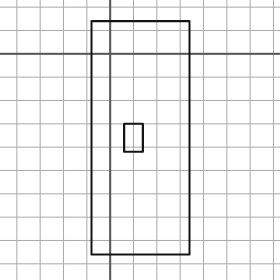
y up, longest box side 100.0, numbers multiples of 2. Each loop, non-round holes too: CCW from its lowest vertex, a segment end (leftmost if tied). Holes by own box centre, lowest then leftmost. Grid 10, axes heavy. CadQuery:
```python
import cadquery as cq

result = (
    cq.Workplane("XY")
    .moveTo(-8.0, -86.0)
    .lineTo(34.0, -86.0)
    .lineTo(34.0, 14.0)
    .lineTo(-8.0, 14.0)
    .close()
    .moveTo(6.0, -42.0)
    .lineTo(14.0, -42.0)
    .lineTo(14.0, -30.0)
    .lineTo(6.0, -30.0)
    .close()
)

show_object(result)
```